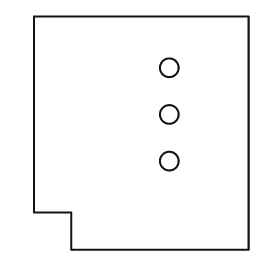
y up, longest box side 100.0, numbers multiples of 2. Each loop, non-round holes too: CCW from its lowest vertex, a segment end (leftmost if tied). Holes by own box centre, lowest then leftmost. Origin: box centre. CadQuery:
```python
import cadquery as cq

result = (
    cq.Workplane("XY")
    .moveTo(-30.0, -50.0)
    .lineTo(46.0, -50.0)
    .lineTo(46.0, 50.0)
    .lineTo(-46.0, 50.0)
    .lineTo(-46.0, -34.0)
    .lineTo(-30.0, -34.0)
    .close()
    .moveTo(12.0, -12.0)
    .circle(4.0)
    .moveTo(12.0, 8.0)
    .circle(4.0)
    .moveTo(12.0, 28.0)
    .circle(4.0)
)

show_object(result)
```